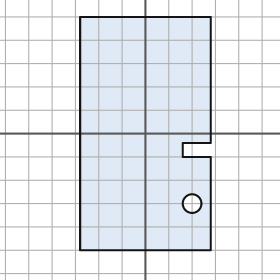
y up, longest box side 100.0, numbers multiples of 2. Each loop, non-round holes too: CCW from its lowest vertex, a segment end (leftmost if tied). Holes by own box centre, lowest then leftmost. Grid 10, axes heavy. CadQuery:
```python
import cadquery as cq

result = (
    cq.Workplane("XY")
    .moveTo(-28.0, -50.0)
    .lineTo(28.0, -50.0)
    .lineTo(28.0, -10.0)
    .lineTo(16.0, -10.0)
    .lineTo(16.0, -4.0)
    .lineTo(28.0, -4.0)
    .lineTo(28.0, 50.0)
    .lineTo(-28.0, 50.0)
    .close()
    .moveTo(20.0, -30.0)
    .circle(4.0)
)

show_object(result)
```